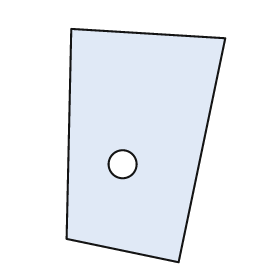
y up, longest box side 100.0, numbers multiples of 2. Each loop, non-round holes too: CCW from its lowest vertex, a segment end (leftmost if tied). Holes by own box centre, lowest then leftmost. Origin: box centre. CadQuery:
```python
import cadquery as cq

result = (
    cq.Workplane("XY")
    .moveTo(14.0, -50.0)
    .lineTo(34.0, 46.0)
    .lineTo(-32.0, 50.0)
    .lineTo(-34.0, -40.0)
    .close()
    .moveTo(-10.0, -8.0)
    .circle(6.0)
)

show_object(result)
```